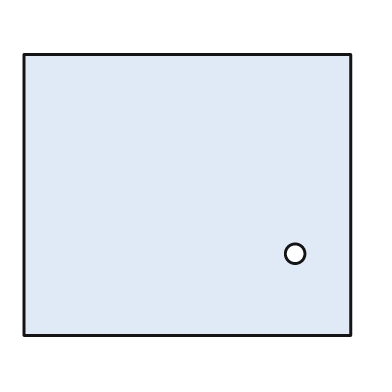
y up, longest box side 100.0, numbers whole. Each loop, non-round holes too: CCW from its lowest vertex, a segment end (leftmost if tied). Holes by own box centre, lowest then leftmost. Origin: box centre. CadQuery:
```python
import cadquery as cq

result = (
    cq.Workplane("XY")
    .moveTo(-50.0, -43.0)
    .lineTo(50.0, -43.0)
    .lineTo(50.0, 43.0)
    .lineTo(-50.0, 43.0)
    .close()
    .moveTo(33.0, -18.0)
    .circle(3.0)
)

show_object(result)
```